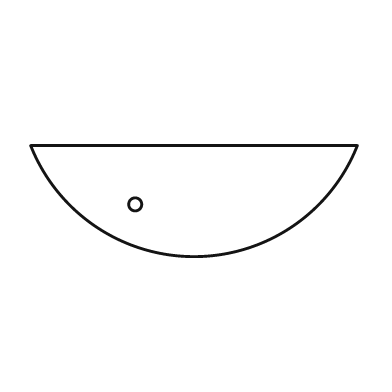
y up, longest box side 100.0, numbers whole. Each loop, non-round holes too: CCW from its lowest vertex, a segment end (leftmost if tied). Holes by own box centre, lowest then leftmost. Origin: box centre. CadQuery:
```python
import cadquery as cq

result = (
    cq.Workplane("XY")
    .moveTo(-50.0, 17.0)
    .threePointArc((0.0, -17.0), (50.0, 17.0))
    .close()
    .moveTo(-18.0, -1.0)
    .circle(2.0)
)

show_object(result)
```